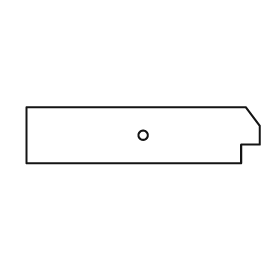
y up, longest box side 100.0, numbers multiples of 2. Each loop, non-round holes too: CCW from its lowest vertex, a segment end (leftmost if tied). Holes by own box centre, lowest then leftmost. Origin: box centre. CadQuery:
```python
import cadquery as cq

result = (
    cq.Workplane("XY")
    .moveTo(-50.0, -12.0)
    .lineTo(42.0, -12.0)
    .lineTo(42.0, -4.0)
    .lineTo(50.0, -4.0)
    .lineTo(50.0, 4.0)
    .lineTo(44.0, 12.0)
    .lineTo(-50.0, 12.0)
    .close()
    .moveTo(0.0, 0.0)
    .circle(2.0)
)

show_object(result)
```